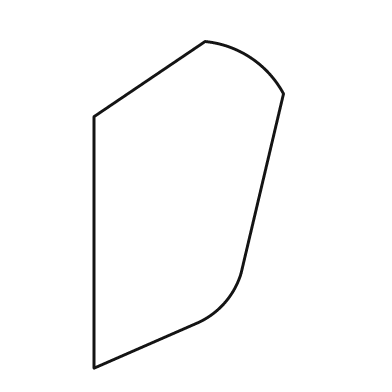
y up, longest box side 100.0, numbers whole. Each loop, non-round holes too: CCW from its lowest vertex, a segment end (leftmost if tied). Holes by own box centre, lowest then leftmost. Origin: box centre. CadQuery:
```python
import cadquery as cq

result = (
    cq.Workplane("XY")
    .moveTo(-29.0, -50.0)
    .lineTo(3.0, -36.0)
    .threePointArc((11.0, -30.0), (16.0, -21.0))
    .lineTo(29.0, 34.0)
    .threePointArc((19.0, 45.0), (5.0, 50.0))
    .lineTo(-29.0, 27.0)
    .close()
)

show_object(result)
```